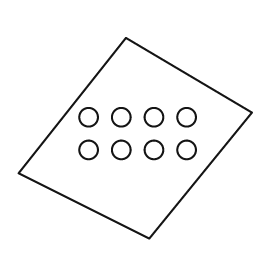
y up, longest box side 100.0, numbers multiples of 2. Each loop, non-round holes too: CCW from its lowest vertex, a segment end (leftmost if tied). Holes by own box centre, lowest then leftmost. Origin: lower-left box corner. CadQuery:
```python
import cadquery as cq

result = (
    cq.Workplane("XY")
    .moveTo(56.0, 0.0)
    .lineTo(100.0, 54.0)
    .lineTo(46.0, 86.0)
    .lineTo(0.0, 28.0)
    .close()
    .moveTo(30.0, 38.0)
    .circle(4.0)
    .moveTo(44.0, 38.0)
    .circle(4.0)
    .moveTo(58.0, 38.0)
    .circle(4.0)
    .moveTo(72.0, 38.0)
    .circle(4.0)
    .moveTo(30.0, 52.0)
    .circle(4.0)
    .moveTo(44.0, 52.0)
    .circle(4.0)
    .moveTo(58.0, 52.0)
    .circle(4.0)
    .moveTo(72.0, 52.0)
    .circle(4.0)
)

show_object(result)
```